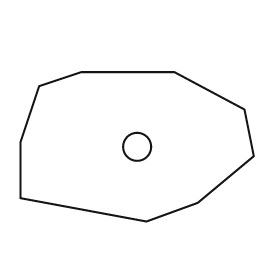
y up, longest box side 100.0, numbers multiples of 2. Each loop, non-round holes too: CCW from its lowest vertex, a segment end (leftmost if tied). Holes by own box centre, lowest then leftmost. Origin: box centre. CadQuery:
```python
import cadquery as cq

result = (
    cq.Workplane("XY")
    .moveTo(4.0, -32.0)
    .lineTo(26.0, -24.0)
    .lineTo(50.0, -4.0)
    .lineTo(46.0, 16.0)
    .lineTo(16.0, 32.0)
    .lineTo(-24.0, 32.0)
    .lineTo(-42.0, 26.0)
    .lineTo(-50.0, 2.0)
    .lineTo(-50.0, -22.0)
    .close()
    .moveTo(0.0, 0.0)
    .circle(6.0)
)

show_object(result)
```